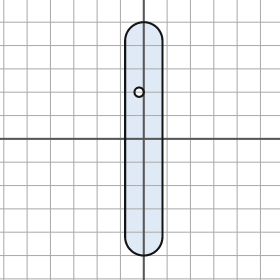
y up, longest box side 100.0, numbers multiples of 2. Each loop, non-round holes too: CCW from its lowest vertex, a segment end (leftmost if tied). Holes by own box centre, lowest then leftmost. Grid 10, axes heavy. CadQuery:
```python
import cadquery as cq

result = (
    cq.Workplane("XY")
    .moveTo(-8.0, -42.0)
    .threePointArc((0.0, -50.0), (8.0, -42.0))
    .lineTo(8.0, 42.0)
    .threePointArc((0.0, 50.0), (-8.0, 42.0))
    .close()
    .moveTo(-2.0, 20.0)
    .circle(2.0)
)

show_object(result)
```